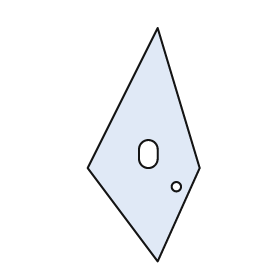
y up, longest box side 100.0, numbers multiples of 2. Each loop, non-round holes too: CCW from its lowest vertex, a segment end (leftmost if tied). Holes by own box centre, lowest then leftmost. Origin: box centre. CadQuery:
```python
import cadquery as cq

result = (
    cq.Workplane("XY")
    .moveTo(6.0, -50.0)
    .lineTo(24.0, -10.0)
    .lineTo(6.0, 50.0)
    .lineTo(-24.0, -10.0)
    .close()
    .moveTo(14.0, -18.0)
    .circle(2.0)
    .moveTo(-2.0, -6.0)
    .threePointArc((2.0, -10.0), (6.0, -6.0))
    .lineTo(6.0, -2.0)
    .threePointArc((2.0, 2.0), (-2.0, -2.0))
    .close()
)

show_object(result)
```